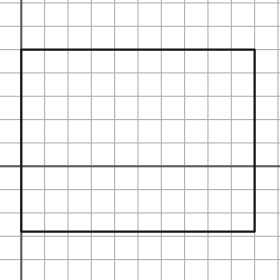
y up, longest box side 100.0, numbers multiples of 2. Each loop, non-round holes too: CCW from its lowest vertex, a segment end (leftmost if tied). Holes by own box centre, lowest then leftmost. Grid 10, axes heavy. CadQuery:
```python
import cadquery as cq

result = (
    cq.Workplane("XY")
    .moveTo(0.0, -28.0)
    .lineTo(100.0, -28.0)
    .lineTo(100.0, 50.0)
    .lineTo(0.0, 50.0)
    .close()
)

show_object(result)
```